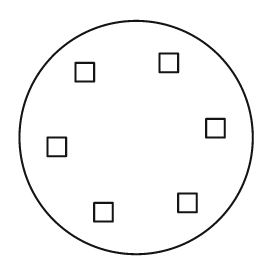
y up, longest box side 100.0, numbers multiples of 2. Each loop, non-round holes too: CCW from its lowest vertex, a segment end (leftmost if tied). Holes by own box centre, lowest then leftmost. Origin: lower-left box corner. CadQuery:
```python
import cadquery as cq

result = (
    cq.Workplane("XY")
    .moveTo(50.0, 50.0)
    .circle(50.0)
    .moveTo(32.0, 14.0)
    .lineTo(40.0, 14.0)
    .lineTo(40.0, 22.0)
    .lineTo(32.0, 22.0)
    .close()
    .moveTo(68.0, 18.0)
    .lineTo(76.0, 18.0)
    .lineTo(76.0, 26.0)
    .lineTo(68.0, 26.0)
    .close()
    .moveTo(12.0, 42.0)
    .lineTo(20.0, 42.0)
    .lineTo(20.0, 50.0)
    .lineTo(12.0, 50.0)
    .close()
    .moveTo(80.0, 50.0)
    .lineTo(88.0, 50.0)
    .lineTo(88.0, 58.0)
    .lineTo(80.0, 58.0)
    .close()
    .moveTo(24.0, 74.0)
    .lineTo(32.0, 74.0)
    .lineTo(32.0, 82.0)
    .lineTo(24.0, 82.0)
    .close()
    .moveTo(60.0, 78.0)
    .lineTo(68.0, 78.0)
    .lineTo(68.0, 86.0)
    .lineTo(60.0, 86.0)
    .close()
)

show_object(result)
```